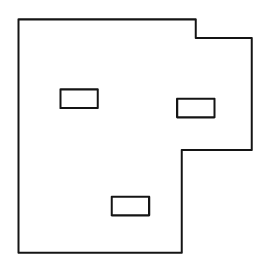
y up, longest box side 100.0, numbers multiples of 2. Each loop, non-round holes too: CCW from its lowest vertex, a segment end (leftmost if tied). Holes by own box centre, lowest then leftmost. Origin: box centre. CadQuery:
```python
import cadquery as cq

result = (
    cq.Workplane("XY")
    .moveTo(-50.0, -50.0)
    .lineTo(20.0, -50.0)
    .lineTo(20.0, -6.0)
    .lineTo(50.0, -6.0)
    .lineTo(50.0, 42.0)
    .lineTo(26.0, 42.0)
    .lineTo(26.0, 50.0)
    .lineTo(-50.0, 50.0)
    .close()
    .moveTo(-10.0, -34.0)
    .lineTo(6.0, -34.0)
    .lineTo(6.0, -26.0)
    .lineTo(-10.0, -26.0)
    .close()
    .moveTo(18.0, 8.0)
    .lineTo(34.0, 8.0)
    .lineTo(34.0, 16.0)
    .lineTo(18.0, 16.0)
    .close()
    .moveTo(-32.0, 12.0)
    .lineTo(-16.0, 12.0)
    .lineTo(-16.0, 20.0)
    .lineTo(-32.0, 20.0)
    .close()
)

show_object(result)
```